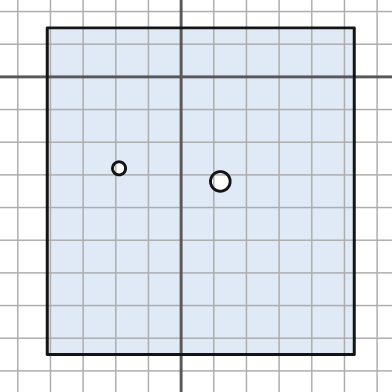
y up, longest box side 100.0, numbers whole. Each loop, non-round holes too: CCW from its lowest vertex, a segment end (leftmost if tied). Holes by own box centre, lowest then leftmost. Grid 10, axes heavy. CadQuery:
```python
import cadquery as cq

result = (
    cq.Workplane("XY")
    .moveTo(-41.0, -85.0)
    .lineTo(53.0, -85.0)
    .lineTo(53.0, 15.0)
    .lineTo(-41.0, 15.0)
    .close()
    .moveTo(12.0, -32.0)
    .circle(3.0)
    .moveTo(-19.0, -28.0)
    .circle(2.0)
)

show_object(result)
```